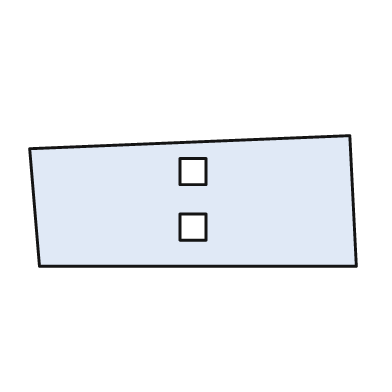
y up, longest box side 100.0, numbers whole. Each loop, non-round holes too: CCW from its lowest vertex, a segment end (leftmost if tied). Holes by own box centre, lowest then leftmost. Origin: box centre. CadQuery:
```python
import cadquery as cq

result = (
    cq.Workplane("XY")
    .moveTo(-47.0, -20.0)
    .lineTo(50.0, -20.0)
    .lineTo(48.0, 20.0)
    .lineTo(-50.0, 16.0)
    .close()
    .moveTo(-4.0, -12.0)
    .lineTo(4.0, -12.0)
    .lineTo(4.0, -4.0)
    .lineTo(-4.0, -4.0)
    .close()
    .moveTo(-4.0, 5.0)
    .lineTo(4.0, 5.0)
    .lineTo(4.0, 13.0)
    .lineTo(-4.0, 13.0)
    .close()
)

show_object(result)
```